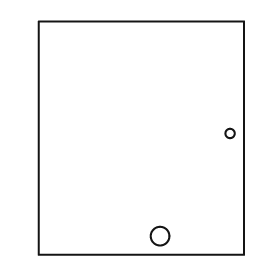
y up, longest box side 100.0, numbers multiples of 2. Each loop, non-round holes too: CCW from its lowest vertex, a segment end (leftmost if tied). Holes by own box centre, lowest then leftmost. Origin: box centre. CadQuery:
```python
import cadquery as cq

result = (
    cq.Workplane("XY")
    .moveTo(-44.0, -50.0)
    .lineTo(44.0, -50.0)
    .lineTo(44.0, 50.0)
    .lineTo(-44.0, 50.0)
    .close()
    .moveTo(8.0, -42.0)
    .circle(4.0)
    .moveTo(38.0, 2.0)
    .circle(2.0)
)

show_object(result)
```